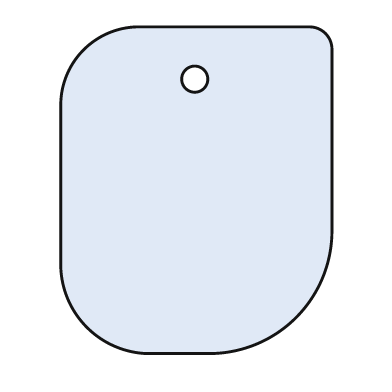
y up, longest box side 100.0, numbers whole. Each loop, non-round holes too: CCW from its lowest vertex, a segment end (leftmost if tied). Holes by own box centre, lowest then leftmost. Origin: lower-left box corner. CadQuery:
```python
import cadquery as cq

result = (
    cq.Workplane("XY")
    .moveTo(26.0, 0.0)
    .lineTo(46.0, 0.0)
    .threePointArc((72.0, 11.0), (83.0, 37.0))
    .lineTo(83.0, 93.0)
    .threePointArc((81.0, 98.0), (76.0, 100.0))
    .lineTo(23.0, 100.0)
    .threePointArc((7.0, 93.0), (0.0, 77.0))
    .lineTo(0.0, 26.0)
    .threePointArc((8.0, 8.0), (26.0, 0.0))
    .close()
    .moveTo(41.0, 84.0)
    .circle(4.0)
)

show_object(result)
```